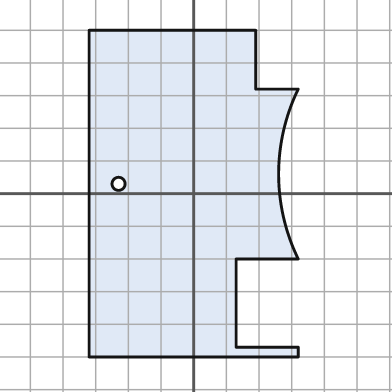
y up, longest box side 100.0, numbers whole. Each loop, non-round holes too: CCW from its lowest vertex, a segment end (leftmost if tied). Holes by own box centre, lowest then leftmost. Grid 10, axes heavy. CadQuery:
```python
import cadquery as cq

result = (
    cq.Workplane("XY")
    .moveTo(-32.0, -50.0)
    .lineTo(32.0, -50.0)
    .lineTo(32.0, -47.0)
    .lineTo(13.0, -47.0)
    .lineTo(13.0, -20.0)
    .lineTo(32.0, -20.0)
    .threePointArc((26.0, 6.0), (32.0, 32.0))
    .lineTo(19.0, 32.0)
    .lineTo(19.0, 50.0)
    .lineTo(-32.0, 50.0)
    .close()
    .moveTo(-23.0, 3.0)
    .circle(2.0)
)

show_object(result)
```